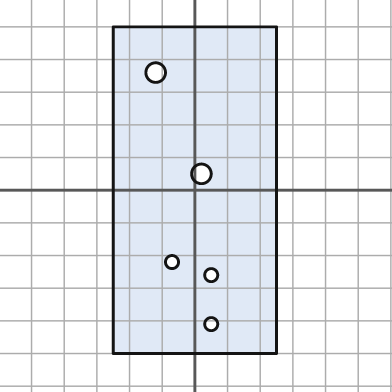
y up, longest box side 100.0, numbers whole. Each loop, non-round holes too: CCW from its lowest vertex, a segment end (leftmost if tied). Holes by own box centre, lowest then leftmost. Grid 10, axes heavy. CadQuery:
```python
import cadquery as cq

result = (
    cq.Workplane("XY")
    .moveTo(-25.0, -50.0)
    .lineTo(25.0, -50.0)
    .lineTo(25.0, 50.0)
    .lineTo(-25.0, 50.0)
    .close()
    .moveTo(5.0, -41.0)
    .circle(2.0)
    .moveTo(5.0, -26.0)
    .circle(2.0)
    .moveTo(-7.0, -22.0)
    .circle(2.0)
    .moveTo(2.0, 5.0)
    .circle(3.0)
    .moveTo(-12.0, 36.0)
    .circle(3.0)
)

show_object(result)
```